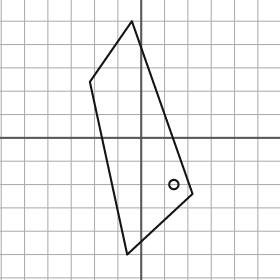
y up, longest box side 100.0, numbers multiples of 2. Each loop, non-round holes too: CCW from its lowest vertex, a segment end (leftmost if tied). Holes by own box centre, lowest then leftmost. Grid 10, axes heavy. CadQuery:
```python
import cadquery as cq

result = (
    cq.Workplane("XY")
    .moveTo(-6.0, -50.0)
    .lineTo(22.0, -24.0)
    .lineTo(-4.0, 50.0)
    .lineTo(-22.0, 24.0)
    .close()
    .moveTo(14.0, -20.0)
    .circle(2.0)
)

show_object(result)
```